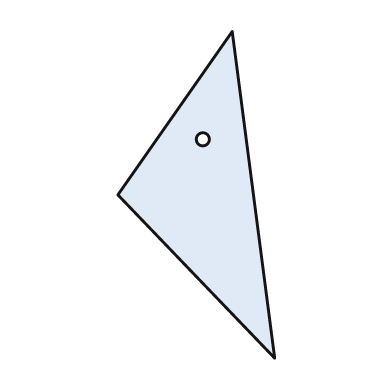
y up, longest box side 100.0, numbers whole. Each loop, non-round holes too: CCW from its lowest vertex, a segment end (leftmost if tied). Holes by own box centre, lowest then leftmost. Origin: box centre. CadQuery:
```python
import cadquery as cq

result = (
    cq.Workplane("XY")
    .moveTo(24.0, -50.0)
    .lineTo(11.0, 50.0)
    .lineTo(-24.0, 0.0)
    .close()
    .moveTo(2.0, 17.0)
    .circle(2.0)
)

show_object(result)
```